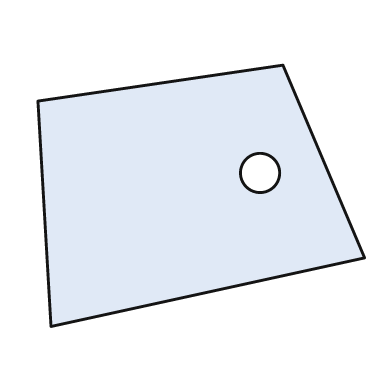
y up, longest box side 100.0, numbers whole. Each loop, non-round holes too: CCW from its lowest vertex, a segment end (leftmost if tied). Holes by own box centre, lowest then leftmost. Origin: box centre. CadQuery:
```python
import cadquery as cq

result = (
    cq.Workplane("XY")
    .moveTo(-46.0, -40.0)
    .lineTo(50.0, -19.0)
    .lineTo(25.0, 40.0)
    .lineTo(-50.0, 29.0)
    .close()
    .moveTo(18.0, 7.0)
    .circle(6.0)
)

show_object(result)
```